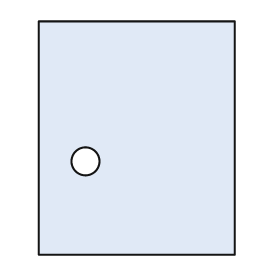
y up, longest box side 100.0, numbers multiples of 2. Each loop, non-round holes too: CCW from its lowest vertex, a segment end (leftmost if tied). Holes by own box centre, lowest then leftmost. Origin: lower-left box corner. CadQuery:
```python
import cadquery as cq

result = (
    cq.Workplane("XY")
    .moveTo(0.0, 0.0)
    .lineTo(84.0, 0.0)
    .lineTo(84.0, 100.0)
    .lineTo(0.0, 100.0)
    .close()
    .moveTo(20.0, 40.0)
    .circle(6.0)
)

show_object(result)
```